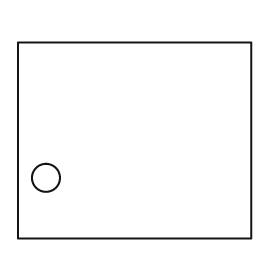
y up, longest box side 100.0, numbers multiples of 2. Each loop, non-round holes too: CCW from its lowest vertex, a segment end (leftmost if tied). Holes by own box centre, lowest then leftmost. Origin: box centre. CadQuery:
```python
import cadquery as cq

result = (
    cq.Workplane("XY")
    .moveTo(-50.0, -42.0)
    .lineTo(50.0, -42.0)
    .lineTo(50.0, 42.0)
    .lineTo(-50.0, 42.0)
    .close()
    .moveTo(-38.0, -16.0)
    .circle(6.0)
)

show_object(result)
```